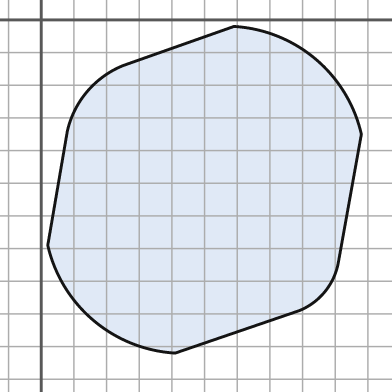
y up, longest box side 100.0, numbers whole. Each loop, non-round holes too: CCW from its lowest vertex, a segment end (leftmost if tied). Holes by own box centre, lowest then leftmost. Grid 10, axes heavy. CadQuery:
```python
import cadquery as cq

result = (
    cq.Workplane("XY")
    .moveTo(41.0, -102.0)
    .lineTo(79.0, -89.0)
    .threePointArc((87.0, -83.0), (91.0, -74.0))
    .lineTo(98.0, -35.0)
    .threePointArc((84.0, -12.0), (59.0, -2.0))
    .lineTo(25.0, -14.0)
    .threePointArc((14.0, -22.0), (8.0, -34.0))
    .lineTo(2.0, -69.0)
    .threePointArc((16.0, -92.0), (41.0, -102.0))
    .close()
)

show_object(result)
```